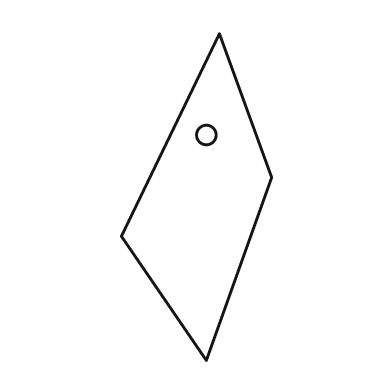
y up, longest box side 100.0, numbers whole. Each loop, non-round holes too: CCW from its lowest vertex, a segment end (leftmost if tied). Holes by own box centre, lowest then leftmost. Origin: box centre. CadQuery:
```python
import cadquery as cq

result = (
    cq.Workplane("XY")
    .moveTo(3.0, -50.0)
    .lineTo(23.0, 6.0)
    .lineTo(7.0, 50.0)
    .lineTo(-23.0, -12.0)
    .close()
    .moveTo(3.0, 19.0)
    .circle(3.0)
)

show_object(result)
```